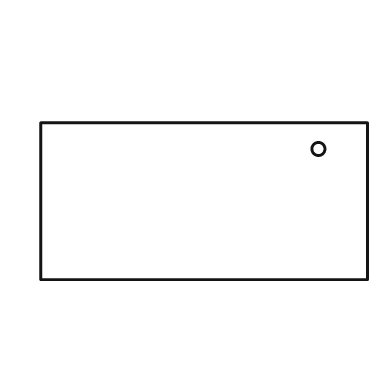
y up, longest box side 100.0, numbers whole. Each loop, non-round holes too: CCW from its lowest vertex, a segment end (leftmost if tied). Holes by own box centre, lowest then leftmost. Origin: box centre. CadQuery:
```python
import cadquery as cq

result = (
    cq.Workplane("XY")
    .moveTo(-50.0, -24.0)
    .lineTo(50.0, -24.0)
    .lineTo(50.0, 24.0)
    .lineTo(-50.0, 24.0)
    .close()
    .moveTo(35.0, 16.0)
    .circle(2.0)
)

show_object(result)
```